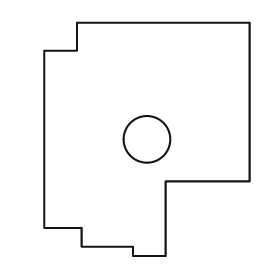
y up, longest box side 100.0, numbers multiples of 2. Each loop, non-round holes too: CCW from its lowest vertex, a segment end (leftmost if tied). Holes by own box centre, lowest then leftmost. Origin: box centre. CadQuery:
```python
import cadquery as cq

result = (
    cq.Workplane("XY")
    .moveTo(-6.0, -50.0)
    .lineTo(8.0, -50.0)
    .lineTo(8.0, -18.0)
    .lineTo(44.0, -18.0)
    .lineTo(44.0, 50.0)
    .lineTo(-30.0, 50.0)
    .lineTo(-30.0, 38.0)
    .lineTo(-44.0, 38.0)
    .lineTo(-44.0, -38.0)
    .lineTo(-28.0, -38.0)
    .lineTo(-28.0, -46.0)
    .lineTo(-6.0, -46.0)
    .close()
    .moveTo(0.0, 0.0)
    .circle(10.0)
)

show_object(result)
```